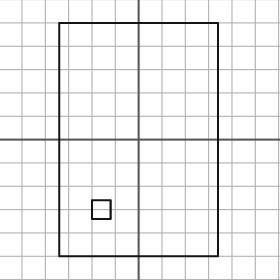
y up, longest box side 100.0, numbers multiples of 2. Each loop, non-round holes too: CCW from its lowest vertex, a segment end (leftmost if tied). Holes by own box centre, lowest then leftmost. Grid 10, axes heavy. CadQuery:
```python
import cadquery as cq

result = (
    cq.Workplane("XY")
    .moveTo(-34.0, -50.0)
    .lineTo(34.0, -50.0)
    .lineTo(34.0, 50.0)
    .lineTo(-34.0, 50.0)
    .close()
    .moveTo(-20.0, -34.0)
    .lineTo(-12.0, -34.0)
    .lineTo(-12.0, -26.0)
    .lineTo(-20.0, -26.0)
    .close()
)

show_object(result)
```